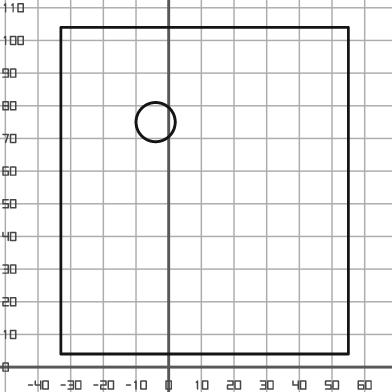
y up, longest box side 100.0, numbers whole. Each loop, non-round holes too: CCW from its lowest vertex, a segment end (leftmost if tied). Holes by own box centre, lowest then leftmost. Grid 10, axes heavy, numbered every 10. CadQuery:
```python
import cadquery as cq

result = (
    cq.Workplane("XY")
    .moveTo(-33.0, 4.0)
    .lineTo(55.0, 4.0)
    .lineTo(55.0, 104.0)
    .lineTo(-33.0, 104.0)
    .close()
    .moveTo(-4.0, 75.0)
    .circle(6.0)
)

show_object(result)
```